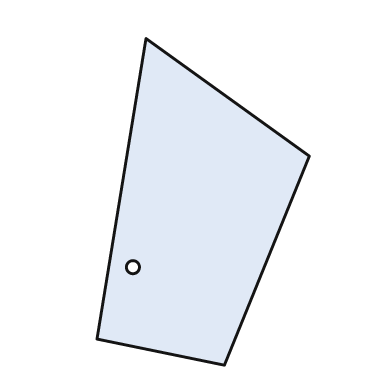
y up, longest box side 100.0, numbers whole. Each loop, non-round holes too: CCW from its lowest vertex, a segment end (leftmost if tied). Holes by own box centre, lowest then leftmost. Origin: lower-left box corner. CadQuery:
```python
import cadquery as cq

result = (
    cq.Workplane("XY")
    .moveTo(39.0, 0.0)
    .lineTo(65.0, 64.0)
    .lineTo(15.0, 100.0)
    .lineTo(0.0, 8.0)
    .close()
    .moveTo(11.0, 30.0)
    .circle(2.0)
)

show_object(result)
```